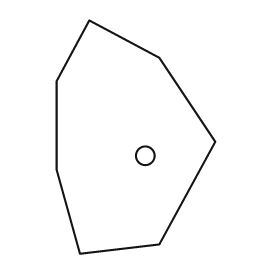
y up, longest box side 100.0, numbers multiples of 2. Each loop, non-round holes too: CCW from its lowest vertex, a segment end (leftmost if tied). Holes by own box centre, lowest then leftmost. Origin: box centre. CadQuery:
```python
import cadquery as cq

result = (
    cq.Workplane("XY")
    .moveTo(-24.0, -50.0)
    .lineTo(10.0, -46.0)
    .lineTo(34.0, -2.0)
    .lineTo(10.0, 34.0)
    .lineTo(-20.0, 50.0)
    .lineTo(-34.0, 24.0)
    .lineTo(-34.0, -14.0)
    .close()
    .moveTo(4.0, -8.0)
    .circle(4.0)
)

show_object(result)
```